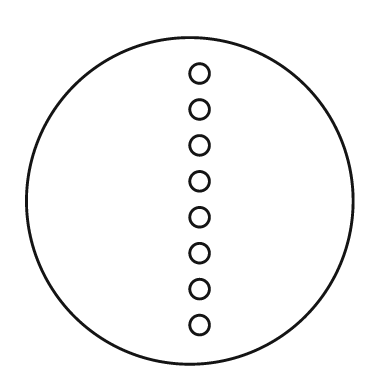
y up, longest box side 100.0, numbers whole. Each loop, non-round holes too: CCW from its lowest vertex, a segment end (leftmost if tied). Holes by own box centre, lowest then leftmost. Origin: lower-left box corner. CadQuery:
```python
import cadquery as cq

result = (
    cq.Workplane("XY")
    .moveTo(50.0, 50.0)
    .circle(50.0)
    .moveTo(53.0, 12.0)
    .circle(3.0)
    .moveTo(53.0, 23.0)
    .circle(3.0)
    .moveTo(53.0, 34.0)
    .circle(3.0)
    .moveTo(53.0, 45.0)
    .circle(3.0)
    .moveTo(53.0, 56.0)
    .circle(3.0)
    .moveTo(53.0, 67.0)
    .circle(3.0)
    .moveTo(53.0, 78.0)
    .circle(3.0)
    .moveTo(53.0, 89.0)
    .circle(3.0)
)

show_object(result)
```